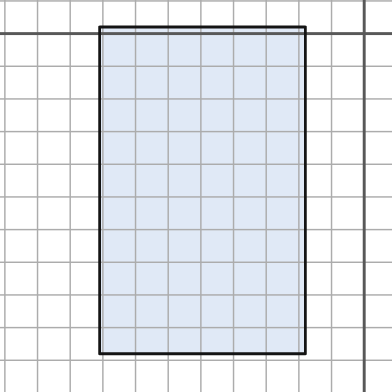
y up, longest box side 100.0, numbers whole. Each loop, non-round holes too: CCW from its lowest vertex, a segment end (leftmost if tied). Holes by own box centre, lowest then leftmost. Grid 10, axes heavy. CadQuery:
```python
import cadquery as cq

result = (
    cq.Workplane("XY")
    .moveTo(-81.0, -98.0)
    .lineTo(-18.0, -98.0)
    .lineTo(-18.0, 2.0)
    .lineTo(-81.0, 2.0)
    .close()
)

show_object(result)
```